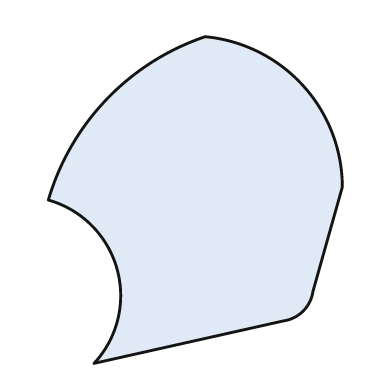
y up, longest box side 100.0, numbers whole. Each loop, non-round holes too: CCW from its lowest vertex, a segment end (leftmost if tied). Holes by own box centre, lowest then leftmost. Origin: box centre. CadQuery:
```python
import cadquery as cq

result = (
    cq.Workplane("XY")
    .moveTo(-31.0, -50.0)
    .lineTo(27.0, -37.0)
    .threePointArc((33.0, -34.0), (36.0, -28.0))
    .lineTo(45.0, 4.0)
    .threePointArc((33.0, 35.0), (3.0, 50.0))
    .threePointArc((-27.0, 31.0), (-45.0, 0.0))
    .threePointArc((-24.0, -21.0), (-31.0, -50.0))
    .close()
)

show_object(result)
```